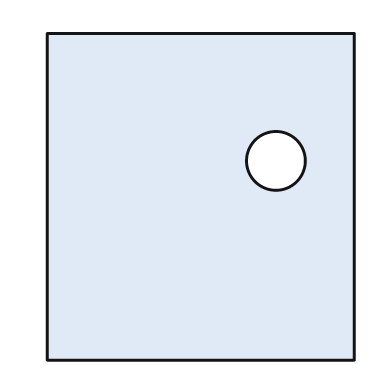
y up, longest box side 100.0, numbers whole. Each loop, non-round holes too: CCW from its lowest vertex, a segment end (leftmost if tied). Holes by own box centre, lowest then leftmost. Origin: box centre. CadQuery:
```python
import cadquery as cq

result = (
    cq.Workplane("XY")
    .moveTo(-47.0, -50.0)
    .lineTo(47.0, -50.0)
    .lineTo(47.0, 50.0)
    .lineTo(-47.0, 50.0)
    .close()
    .moveTo(23.0, 11.0)
    .circle(9.0)
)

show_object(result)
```